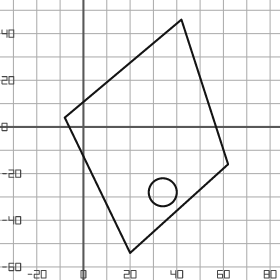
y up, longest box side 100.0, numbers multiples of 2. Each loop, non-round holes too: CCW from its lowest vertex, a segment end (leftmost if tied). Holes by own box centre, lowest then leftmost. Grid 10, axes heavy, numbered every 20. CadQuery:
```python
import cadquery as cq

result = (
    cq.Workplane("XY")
    .moveTo(20.0, -54.0)
    .lineTo(62.0, -16.0)
    .lineTo(42.0, 46.0)
    .lineTo(-8.0, 4.0)
    .close()
    .moveTo(34.0, -28.0)
    .circle(6.0)
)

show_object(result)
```